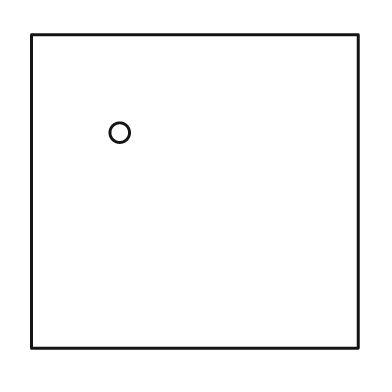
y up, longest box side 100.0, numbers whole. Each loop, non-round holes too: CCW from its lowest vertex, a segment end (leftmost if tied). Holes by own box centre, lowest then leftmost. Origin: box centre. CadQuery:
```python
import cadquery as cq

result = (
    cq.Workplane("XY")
    .moveTo(-50.0, -48.0)
    .lineTo(50.0, -48.0)
    .lineTo(50.0, 48.0)
    .lineTo(-50.0, 48.0)
    .close()
    .moveTo(-23.0, 18.0)
    .circle(3.0)
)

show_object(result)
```